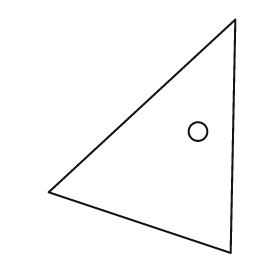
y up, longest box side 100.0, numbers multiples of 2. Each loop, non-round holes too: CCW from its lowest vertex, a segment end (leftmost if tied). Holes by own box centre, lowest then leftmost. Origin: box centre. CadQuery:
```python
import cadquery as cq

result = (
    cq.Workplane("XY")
    .moveTo(38.0, -50.0)
    .lineTo(40.0, 50.0)
    .lineTo(-40.0, -24.0)
    .close()
    .moveTo(24.0, 2.0)
    .circle(4.0)
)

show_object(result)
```